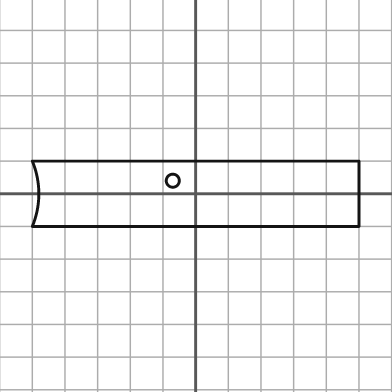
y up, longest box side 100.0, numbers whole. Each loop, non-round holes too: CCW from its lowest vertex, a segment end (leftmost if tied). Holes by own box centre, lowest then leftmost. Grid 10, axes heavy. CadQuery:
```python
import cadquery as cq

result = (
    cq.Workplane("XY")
    .moveTo(-50.0, -10.0)
    .lineTo(50.0, -10.0)
    .lineTo(50.0, 10.0)
    .lineTo(-50.0, 10.0)
    .threePointArc((-48.0, 0.0), (-50.0, -10.0))
    .close()
    .moveTo(-7.0, 4.0)
    .circle(2.0)
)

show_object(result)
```